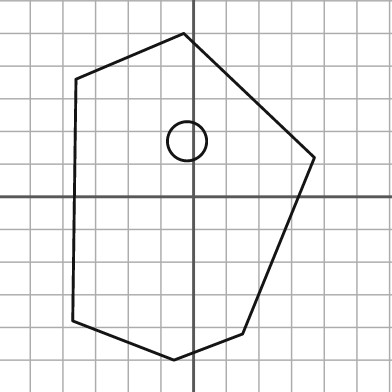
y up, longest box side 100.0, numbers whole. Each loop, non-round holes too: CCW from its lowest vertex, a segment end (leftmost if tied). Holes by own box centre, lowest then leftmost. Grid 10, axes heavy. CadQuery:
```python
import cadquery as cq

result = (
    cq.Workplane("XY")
    .moveTo(-6.0, -50.0)
    .lineTo(15.0, -42.0)
    .lineTo(37.0, 12.0)
    .lineTo(-3.0, 50.0)
    .lineTo(-36.0, 36.0)
    .lineTo(-37.0, -38.0)
    .close()
    .moveTo(-2.0, 17.0)
    .circle(6.0)
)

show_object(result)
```